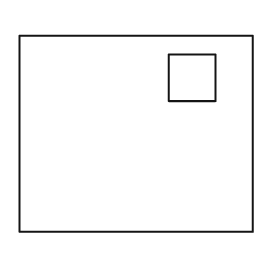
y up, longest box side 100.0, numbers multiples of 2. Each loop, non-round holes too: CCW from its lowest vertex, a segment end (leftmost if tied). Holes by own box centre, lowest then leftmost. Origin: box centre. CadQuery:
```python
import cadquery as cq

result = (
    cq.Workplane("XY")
    .moveTo(-50.0, -42.0)
    .lineTo(50.0, -42.0)
    .lineTo(50.0, 42.0)
    .lineTo(-50.0, 42.0)
    .close()
    .moveTo(14.0, 14.0)
    .lineTo(34.0, 14.0)
    .lineTo(34.0, 34.0)
    .lineTo(14.0, 34.0)
    .close()
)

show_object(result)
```